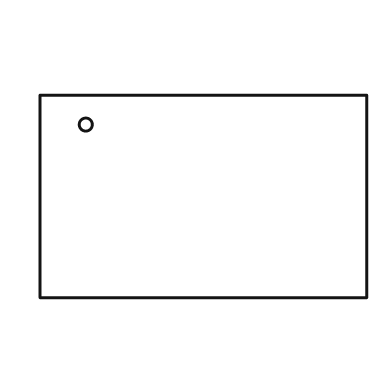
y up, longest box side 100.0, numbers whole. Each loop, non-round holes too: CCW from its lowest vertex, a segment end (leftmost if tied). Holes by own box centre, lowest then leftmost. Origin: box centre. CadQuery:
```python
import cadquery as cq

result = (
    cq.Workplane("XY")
    .moveTo(-50.0, -31.0)
    .lineTo(50.0, -31.0)
    .lineTo(50.0, 31.0)
    .lineTo(-50.0, 31.0)
    .close()
    .moveTo(-36.0, 22.0)
    .circle(2.0)
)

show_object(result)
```